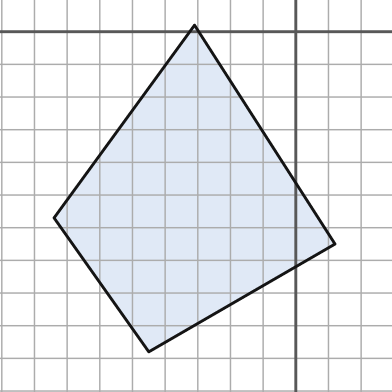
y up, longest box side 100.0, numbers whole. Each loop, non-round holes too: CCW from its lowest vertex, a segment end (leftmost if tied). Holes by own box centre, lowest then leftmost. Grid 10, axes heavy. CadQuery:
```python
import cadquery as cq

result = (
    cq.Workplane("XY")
    .moveTo(-45.0, -98.0)
    .lineTo(12.0, -65.0)
    .lineTo(-31.0, 2.0)
    .lineTo(-74.0, -57.0)
    .close()
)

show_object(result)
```